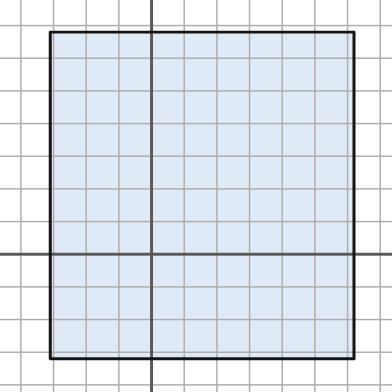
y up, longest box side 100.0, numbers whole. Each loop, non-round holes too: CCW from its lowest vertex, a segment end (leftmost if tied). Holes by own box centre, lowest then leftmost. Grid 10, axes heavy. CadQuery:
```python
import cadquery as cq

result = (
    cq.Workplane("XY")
    .moveTo(-31.0, -32.0)
    .lineTo(62.0, -32.0)
    .lineTo(62.0, 68.0)
    .lineTo(-31.0, 68.0)
    .close()
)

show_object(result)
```